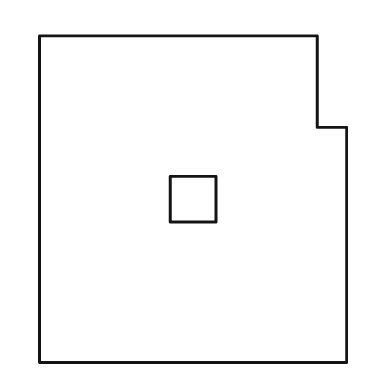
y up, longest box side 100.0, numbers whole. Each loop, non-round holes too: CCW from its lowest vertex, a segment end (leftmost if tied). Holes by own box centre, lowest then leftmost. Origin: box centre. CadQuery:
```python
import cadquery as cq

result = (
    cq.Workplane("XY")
    .moveTo(-47.0, -50.0)
    .lineTo(47.0, -50.0)
    .lineTo(47.0, 22.0)
    .lineTo(38.0, 22.0)
    .lineTo(38.0, 50.0)
    .lineTo(-47.0, 50.0)
    .close()
    .moveTo(-7.0, -7.0)
    .lineTo(7.0, -7.0)
    .lineTo(7.0, 7.0)
    .lineTo(-7.0, 7.0)
    .close()
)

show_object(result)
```